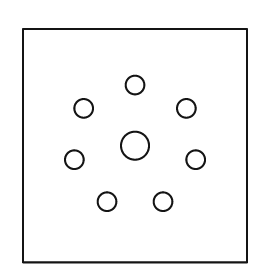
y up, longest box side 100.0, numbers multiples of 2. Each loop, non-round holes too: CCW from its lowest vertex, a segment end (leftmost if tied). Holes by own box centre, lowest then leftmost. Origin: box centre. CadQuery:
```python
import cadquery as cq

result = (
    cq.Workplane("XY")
    .moveTo(-48.0, -50.0)
    .lineTo(48.0, -50.0)
    .lineTo(48.0, 50.0)
    .lineTo(-48.0, 50.0)
    .close()
    .moveTo(-12.0, -24.0)
    .circle(4.0)
    .moveTo(12.0, -24.0)
    .circle(4.0)
    .moveTo(-26.0, -6.0)
    .circle(4.0)
    .moveTo(26.0, -6.0)
    .circle(4.0)
    .moveTo(0.0, 0.0)
    .circle(6.0)
    .moveTo(-22.0, 16.0)
    .circle(4.0)
    .moveTo(22.0, 16.0)
    .circle(4.0)
    .moveTo(0.0, 26.0)
    .circle(4.0)
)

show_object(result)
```